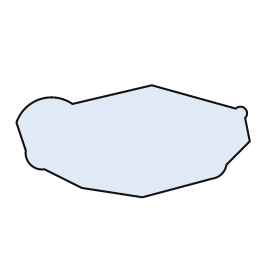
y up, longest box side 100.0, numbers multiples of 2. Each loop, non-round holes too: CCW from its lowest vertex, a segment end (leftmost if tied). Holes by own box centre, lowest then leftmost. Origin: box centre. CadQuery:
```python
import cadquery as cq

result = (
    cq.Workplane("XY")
    .moveTo(4.0, -24.0)
    .lineTo(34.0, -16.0)
    .threePointArc((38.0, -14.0), (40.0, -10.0))
    .lineTo(50.0, 0.0)
    .lineTo(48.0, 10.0)
    .threePointArc((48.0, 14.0), (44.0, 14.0))
    .lineTo(8.0, 24.0)
    .lineTo(-26.0, 16.0)
    .threePointArc((-40.0, 18.0), (-50.0, 8.0))
    .lineTo(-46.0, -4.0)
    .threePointArc((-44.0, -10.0), (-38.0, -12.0))
    .lineTo(-22.0, -20.0)
    .close()
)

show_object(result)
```